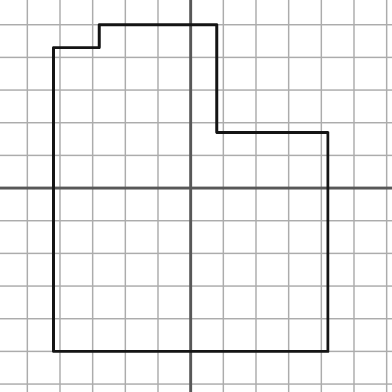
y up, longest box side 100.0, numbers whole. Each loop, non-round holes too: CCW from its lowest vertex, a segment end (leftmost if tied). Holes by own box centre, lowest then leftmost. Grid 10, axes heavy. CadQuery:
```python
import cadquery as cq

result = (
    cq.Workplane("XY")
    .moveTo(-42.0, -50.0)
    .lineTo(42.0, -50.0)
    .lineTo(42.0, 17.0)
    .lineTo(8.0, 17.0)
    .lineTo(8.0, 50.0)
    .lineTo(-28.0, 50.0)
    .lineTo(-28.0, 43.0)
    .lineTo(-42.0, 43.0)
    .close()
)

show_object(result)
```